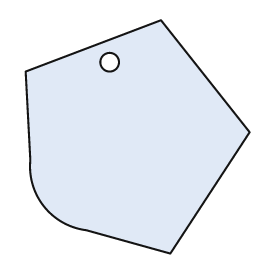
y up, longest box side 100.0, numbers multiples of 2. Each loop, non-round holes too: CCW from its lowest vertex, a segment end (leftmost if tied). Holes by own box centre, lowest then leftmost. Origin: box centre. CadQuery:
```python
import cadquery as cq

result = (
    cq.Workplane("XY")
    .moveTo(14.0, -50.0)
    .lineTo(48.0, 2.0)
    .lineTo(10.0, 50.0)
    .lineTo(-48.0, 28.0)
    .lineTo(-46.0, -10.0)
    .threePointArc((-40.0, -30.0), (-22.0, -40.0))
    .close()
    .moveTo(-12.0, 32.0)
    .circle(4.0)
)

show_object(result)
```